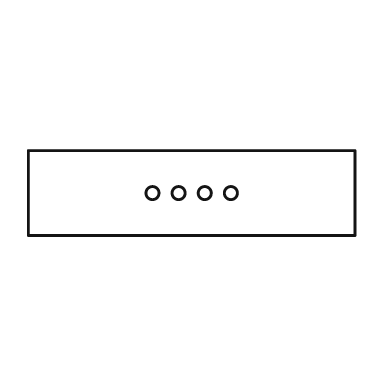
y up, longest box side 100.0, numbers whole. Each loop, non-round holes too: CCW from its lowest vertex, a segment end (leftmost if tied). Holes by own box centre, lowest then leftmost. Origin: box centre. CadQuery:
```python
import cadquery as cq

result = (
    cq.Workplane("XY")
    .moveTo(-50.0, -13.0)
    .lineTo(50.0, -13.0)
    .lineTo(50.0, 13.0)
    .lineTo(-50.0, 13.0)
    .close()
    .moveTo(-12.0, 0.0)
    .circle(2.0)
    .moveTo(-4.0, 0.0)
    .circle(2.0)
    .moveTo(4.0, 0.0)
    .circle(2.0)
    .moveTo(12.0, 0.0)
    .circle(2.0)
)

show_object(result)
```